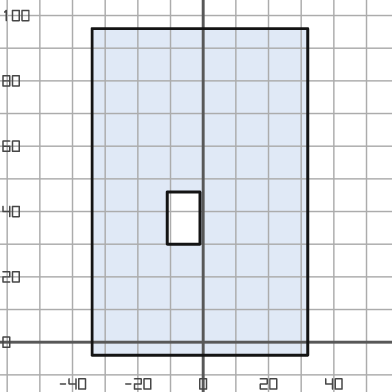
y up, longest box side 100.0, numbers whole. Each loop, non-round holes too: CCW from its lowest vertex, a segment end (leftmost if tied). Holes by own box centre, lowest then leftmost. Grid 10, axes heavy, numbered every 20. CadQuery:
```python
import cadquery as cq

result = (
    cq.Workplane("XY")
    .moveTo(-34.0, -4.0)
    .lineTo(32.0, -4.0)
    .lineTo(32.0, 96.0)
    .lineTo(-34.0, 96.0)
    .close()
    .moveTo(-11.0, 30.0)
    .lineTo(-1.0, 30.0)
    .lineTo(-1.0, 46.0)
    .lineTo(-11.0, 46.0)
    .close()
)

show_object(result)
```